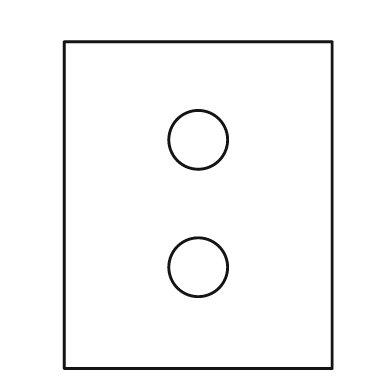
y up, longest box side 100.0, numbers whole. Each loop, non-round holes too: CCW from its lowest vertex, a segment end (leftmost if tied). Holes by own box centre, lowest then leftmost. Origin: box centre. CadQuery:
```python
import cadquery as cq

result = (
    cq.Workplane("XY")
    .moveTo(-41.0, -50.0)
    .lineTo(41.0, -50.0)
    .lineTo(41.0, 50.0)
    .lineTo(-41.0, 50.0)
    .close()
    .moveTo(0.0, -19.0)
    .circle(9.0)
    .moveTo(0.0, 20.0)
    .circle(9.0)
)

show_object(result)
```